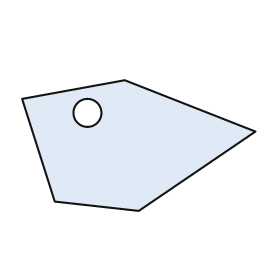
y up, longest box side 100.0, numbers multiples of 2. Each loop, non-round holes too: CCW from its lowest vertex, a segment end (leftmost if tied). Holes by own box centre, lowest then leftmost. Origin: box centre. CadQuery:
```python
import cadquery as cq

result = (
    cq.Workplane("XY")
    .moveTo(0.0, -28.0)
    .lineTo(50.0, 6.0)
    .lineTo(-6.0, 28.0)
    .lineTo(-50.0, 20.0)
    .lineTo(-36.0, -24.0)
    .close()
    .moveTo(-22.0, 14.0)
    .circle(6.0)
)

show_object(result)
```